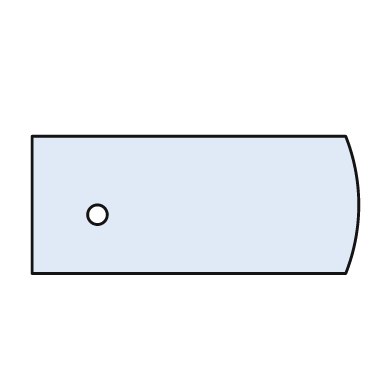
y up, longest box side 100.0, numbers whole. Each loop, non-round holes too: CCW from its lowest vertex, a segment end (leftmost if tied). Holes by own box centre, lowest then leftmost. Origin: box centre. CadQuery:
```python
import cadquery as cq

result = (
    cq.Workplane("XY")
    .moveTo(-50.0, -21.0)
    .lineTo(46.0, -21.0)
    .threePointArc((50.0, 0.0), (46.0, 21.0))
    .lineTo(-50.0, 21.0)
    .close()
    .moveTo(-30.0, -3.0)
    .circle(3.0)
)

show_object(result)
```